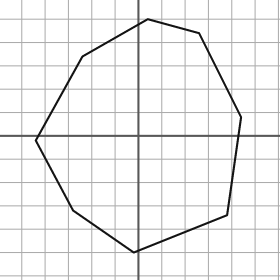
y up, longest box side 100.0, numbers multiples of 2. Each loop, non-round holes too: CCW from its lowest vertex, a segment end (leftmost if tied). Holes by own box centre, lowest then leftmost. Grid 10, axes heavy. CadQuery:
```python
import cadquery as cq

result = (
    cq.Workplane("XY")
    .moveTo(-2.0, -50.0)
    .lineTo(38.0, -34.0)
    .lineTo(44.0, 8.0)
    .lineTo(26.0, 44.0)
    .lineTo(4.0, 50.0)
    .lineTo(-24.0, 34.0)
    .lineTo(-44.0, -2.0)
    .lineTo(-28.0, -32.0)
    .close()
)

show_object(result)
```